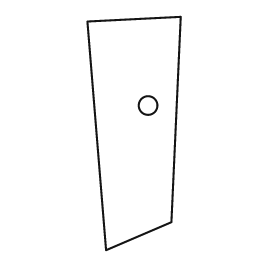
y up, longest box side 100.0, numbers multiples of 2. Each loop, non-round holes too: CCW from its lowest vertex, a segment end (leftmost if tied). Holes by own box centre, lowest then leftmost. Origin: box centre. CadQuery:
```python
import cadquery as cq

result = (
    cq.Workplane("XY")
    .moveTo(-12.0, -50.0)
    .lineTo(16.0, -38.0)
    .lineTo(20.0, 50.0)
    .lineTo(-20.0, 48.0)
    .close()
    .moveTo(6.0, 12.0)
    .circle(4.0)
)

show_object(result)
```